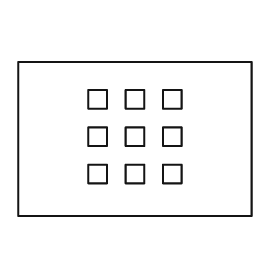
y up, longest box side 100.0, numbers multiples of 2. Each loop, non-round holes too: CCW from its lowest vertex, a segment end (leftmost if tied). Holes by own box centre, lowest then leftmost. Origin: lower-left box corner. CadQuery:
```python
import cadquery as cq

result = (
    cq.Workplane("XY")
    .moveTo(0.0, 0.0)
    .lineTo(100.0, 0.0)
    .lineTo(100.0, 66.0)
    .lineTo(0.0, 66.0)
    .close()
    .moveTo(30.0, 14.0)
    .lineTo(38.0, 14.0)
    .lineTo(38.0, 22.0)
    .lineTo(30.0, 22.0)
    .close()
    .moveTo(46.0, 14.0)
    .lineTo(54.0, 14.0)
    .lineTo(54.0, 22.0)
    .lineTo(46.0, 22.0)
    .close()
    .moveTo(62.0, 14.0)
    .lineTo(70.0, 14.0)
    .lineTo(70.0, 22.0)
    .lineTo(62.0, 22.0)
    .close()
    .moveTo(30.0, 30.0)
    .lineTo(38.0, 30.0)
    .lineTo(38.0, 38.0)
    .lineTo(30.0, 38.0)
    .close()
    .moveTo(46.0, 30.0)
    .lineTo(54.0, 30.0)
    .lineTo(54.0, 38.0)
    .lineTo(46.0, 38.0)
    .close()
    .moveTo(62.0, 30.0)
    .lineTo(70.0, 30.0)
    .lineTo(70.0, 38.0)
    .lineTo(62.0, 38.0)
    .close()
    .moveTo(30.0, 46.0)
    .lineTo(38.0, 46.0)
    .lineTo(38.0, 54.0)
    .lineTo(30.0, 54.0)
    .close()
    .moveTo(46.0, 46.0)
    .lineTo(54.0, 46.0)
    .lineTo(54.0, 54.0)
    .lineTo(46.0, 54.0)
    .close()
    .moveTo(62.0, 46.0)
    .lineTo(70.0, 46.0)
    .lineTo(70.0, 54.0)
    .lineTo(62.0, 54.0)
    .close()
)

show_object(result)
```